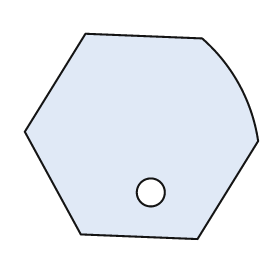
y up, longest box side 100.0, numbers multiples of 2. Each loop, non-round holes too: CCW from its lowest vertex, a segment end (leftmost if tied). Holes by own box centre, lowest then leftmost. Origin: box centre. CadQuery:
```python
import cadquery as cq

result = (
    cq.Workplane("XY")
    .moveTo(24.0, -44.0)
    .lineTo(50.0, -2.0)
    .threePointArc((42.0, 22.0), (26.0, 42.0))
    .lineTo(-24.0, 44.0)
    .lineTo(-50.0, 2.0)
    .lineTo(-26.0, -42.0)
    .close()
    .moveTo(4.0, -24.0)
    .circle(6.0)
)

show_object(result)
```